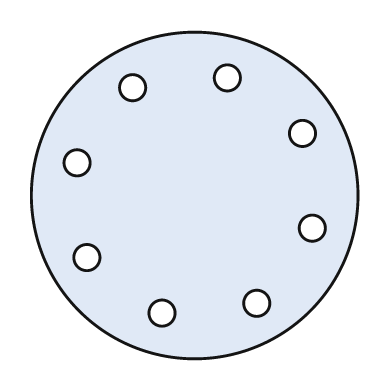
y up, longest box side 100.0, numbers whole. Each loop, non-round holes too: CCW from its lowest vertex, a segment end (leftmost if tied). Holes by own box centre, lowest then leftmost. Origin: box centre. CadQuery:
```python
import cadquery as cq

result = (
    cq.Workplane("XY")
    .moveTo(0.0, 0.0)
    .circle(50.0)
    .moveTo(-10.0, -36.0)
    .circle(4.0)
    .moveTo(19.0, -33.0)
    .circle(4.0)
    .moveTo(-33.0, -19.0)
    .circle(4.0)
    .moveTo(36.0, -10.0)
    .circle(4.0)
    .moveTo(-36.0, 10.0)
    .circle(4.0)
    .moveTo(33.0, 19.0)
    .circle(4.0)
    .moveTo(-19.0, 33.0)
    .circle(4.0)
    .moveTo(10.0, 36.0)
    .circle(4.0)
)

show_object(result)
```